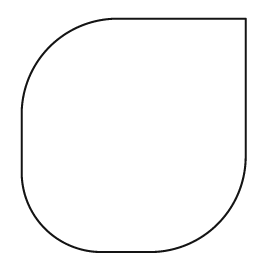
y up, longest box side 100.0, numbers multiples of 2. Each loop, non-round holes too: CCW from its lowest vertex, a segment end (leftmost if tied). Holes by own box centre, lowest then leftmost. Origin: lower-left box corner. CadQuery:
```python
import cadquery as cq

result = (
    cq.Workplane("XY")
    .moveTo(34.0, 0.0)
    .lineTo(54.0, 0.0)
    .threePointArc((84.0, 12.0), (96.0, 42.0))
    .lineTo(96.0, 100.0)
    .lineTo(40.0, 100.0)
    .threePointArc((12.0, 88.0), (0.0, 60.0))
    .lineTo(0.0, 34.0)
    .threePointArc((10.0, 10.0), (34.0, 0.0))
    .close()
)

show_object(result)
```